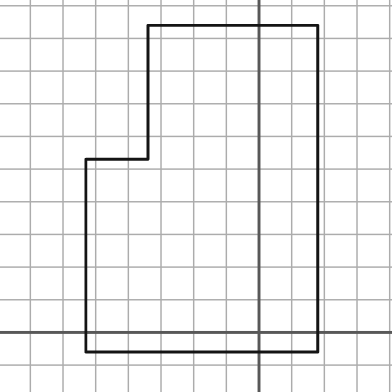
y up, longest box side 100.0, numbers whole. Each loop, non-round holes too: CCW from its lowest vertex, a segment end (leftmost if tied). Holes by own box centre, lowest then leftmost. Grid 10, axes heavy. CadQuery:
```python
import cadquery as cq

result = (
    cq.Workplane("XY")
    .moveTo(-53.0, -6.0)
    .lineTo(18.0, -6.0)
    .lineTo(18.0, 94.0)
    .lineTo(-34.0, 94.0)
    .lineTo(-34.0, 53.0)
    .lineTo(-53.0, 53.0)
    .close()
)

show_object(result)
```